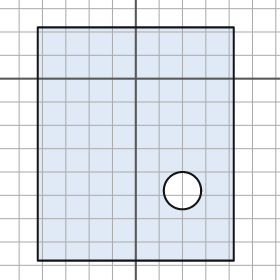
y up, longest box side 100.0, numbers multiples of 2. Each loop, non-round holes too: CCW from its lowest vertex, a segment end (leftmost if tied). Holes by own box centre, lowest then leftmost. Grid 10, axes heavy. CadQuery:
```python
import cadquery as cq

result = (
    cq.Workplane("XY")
    .moveTo(-42.0, -78.0)
    .lineTo(42.0, -78.0)
    .lineTo(42.0, 22.0)
    .lineTo(-42.0, 22.0)
    .close()
    .moveTo(20.0, -48.0)
    .circle(8.0)
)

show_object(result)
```